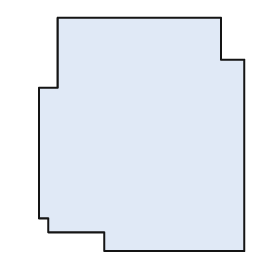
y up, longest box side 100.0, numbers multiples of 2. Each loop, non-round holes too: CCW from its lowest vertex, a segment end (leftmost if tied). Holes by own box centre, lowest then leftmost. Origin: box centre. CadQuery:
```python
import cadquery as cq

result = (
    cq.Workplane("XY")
    .moveTo(-16.0, -50.0)
    .lineTo(44.0, -50.0)
    .lineTo(44.0, 32.0)
    .lineTo(34.0, 32.0)
    .lineTo(34.0, 50.0)
    .lineTo(-36.0, 50.0)
    .lineTo(-36.0, 20.0)
    .lineTo(-44.0, 20.0)
    .lineTo(-44.0, -36.0)
    .lineTo(-40.0, -36.0)
    .lineTo(-40.0, -42.0)
    .lineTo(-16.0, -42.0)
    .close()
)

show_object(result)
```